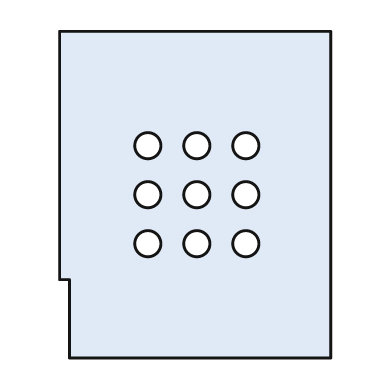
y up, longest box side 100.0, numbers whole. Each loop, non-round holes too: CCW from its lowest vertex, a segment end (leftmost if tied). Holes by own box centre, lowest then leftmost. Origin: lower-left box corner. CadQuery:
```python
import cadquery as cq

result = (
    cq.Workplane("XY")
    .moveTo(3.0, 0.0)
    .lineTo(83.0, 0.0)
    .lineTo(83.0, 100.0)
    .lineTo(0.0, 100.0)
    .lineTo(0.0, 24.0)
    .lineTo(3.0, 24.0)
    .close()
    .moveTo(27.0, 35.0)
    .circle(4.0)
    .moveTo(42.0, 35.0)
    .circle(4.0)
    .moveTo(57.0, 35.0)
    .circle(4.0)
    .moveTo(27.0, 50.0)
    .circle(4.0)
    .moveTo(42.0, 50.0)
    .circle(4.0)
    .moveTo(57.0, 50.0)
    .circle(4.0)
    .moveTo(27.0, 65.0)
    .circle(4.0)
    .moveTo(42.0, 65.0)
    .circle(4.0)
    .moveTo(57.0, 65.0)
    .circle(4.0)
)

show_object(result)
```